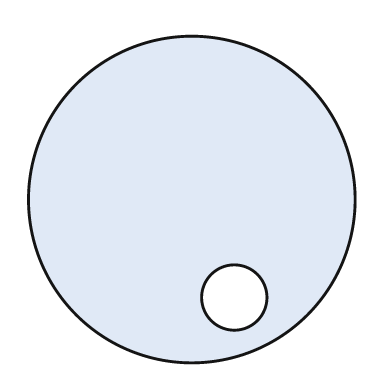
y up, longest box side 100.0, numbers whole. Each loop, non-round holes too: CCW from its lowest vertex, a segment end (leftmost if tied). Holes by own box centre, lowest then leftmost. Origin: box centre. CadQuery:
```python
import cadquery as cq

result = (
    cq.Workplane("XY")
    .moveTo(0.0, 0.0)
    .circle(50.0)
    .moveTo(13.0, -30.0)
    .circle(10.0)
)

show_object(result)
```